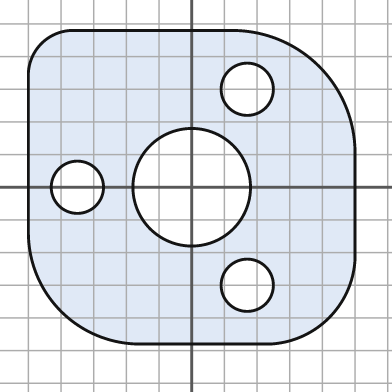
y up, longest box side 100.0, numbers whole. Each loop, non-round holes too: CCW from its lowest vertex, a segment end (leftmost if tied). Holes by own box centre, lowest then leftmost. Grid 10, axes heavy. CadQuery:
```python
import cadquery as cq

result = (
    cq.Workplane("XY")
    .moveTo(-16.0, -48.0)
    .lineTo(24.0, -48.0)
    .threePointArc((42.0, -40.0), (50.0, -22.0))
    .lineTo(50.0, 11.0)
    .threePointArc((39.0, 37.0), (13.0, 48.0))
    .lineTo(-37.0, 48.0)
    .threePointArc((-46.0, 44.0), (-50.0, 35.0))
    .lineTo(-50.0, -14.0)
    .threePointArc((-40.0, -38.0), (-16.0, -48.0))
    .close()
    .moveTo(17.0, -30.0)
    .circle(8.0)
    .moveTo(-35.0, 0.0)
    .circle(8.0)
    .moveTo(0.0, 0.0)
    .circle(18.0)
    .moveTo(17.0, 30.0)
    .circle(8.0)
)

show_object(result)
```